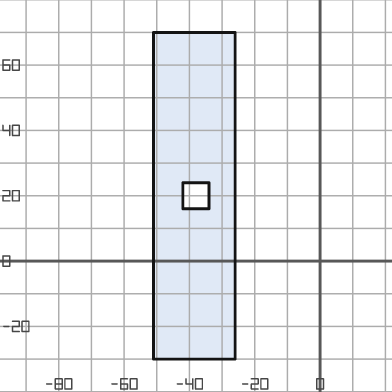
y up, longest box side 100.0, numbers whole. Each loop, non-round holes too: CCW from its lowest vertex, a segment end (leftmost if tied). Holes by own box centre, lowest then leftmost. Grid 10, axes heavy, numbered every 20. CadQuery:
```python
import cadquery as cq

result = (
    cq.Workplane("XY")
    .moveTo(-51.0, -30.0)
    .lineTo(-26.0, -30.0)
    .lineTo(-26.0, 70.0)
    .lineTo(-51.0, 70.0)
    .close()
    .moveTo(-42.0, 16.0)
    .lineTo(-34.0, 16.0)
    .lineTo(-34.0, 24.0)
    .lineTo(-42.0, 24.0)
    .close()
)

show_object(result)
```